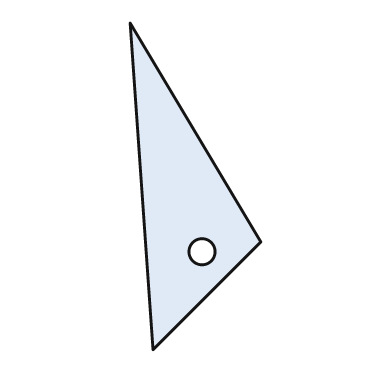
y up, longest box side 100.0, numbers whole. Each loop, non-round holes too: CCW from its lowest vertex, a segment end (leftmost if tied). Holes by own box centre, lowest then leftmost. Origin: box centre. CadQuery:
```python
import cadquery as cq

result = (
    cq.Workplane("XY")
    .moveTo(-13.0, -50.0)
    .lineTo(20.0, -17.0)
    .lineTo(-20.0, 50.0)
    .close()
    .moveTo(2.0, -20.0)
    .circle(4.0)
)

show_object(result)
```